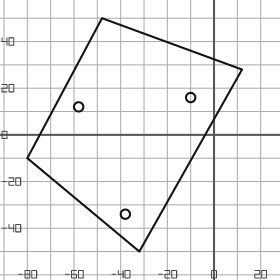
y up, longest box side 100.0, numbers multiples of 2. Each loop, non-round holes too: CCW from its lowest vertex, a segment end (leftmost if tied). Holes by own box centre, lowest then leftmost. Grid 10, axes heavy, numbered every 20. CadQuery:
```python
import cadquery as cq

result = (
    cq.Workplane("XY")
    .moveTo(-32.0, -50.0)
    .lineTo(12.0, 28.0)
    .lineTo(-48.0, 50.0)
    .lineTo(-80.0, -10.0)
    .close()
    .moveTo(-38.0, -34.0)
    .circle(2.0)
    .moveTo(-58.0, 12.0)
    .circle(2.0)
    .moveTo(-10.0, 16.0)
    .circle(2.0)
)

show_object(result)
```